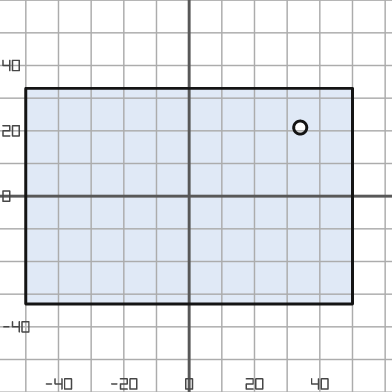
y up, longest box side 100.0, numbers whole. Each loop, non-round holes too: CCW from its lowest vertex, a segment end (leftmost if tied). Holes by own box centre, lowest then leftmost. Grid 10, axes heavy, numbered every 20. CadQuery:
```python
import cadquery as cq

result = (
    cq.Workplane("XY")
    .moveTo(-50.0, -33.0)
    .lineTo(50.0, -33.0)
    .lineTo(50.0, 33.0)
    .lineTo(-50.0, 33.0)
    .close()
    .moveTo(34.0, 21.0)
    .circle(2.0)
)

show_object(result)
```